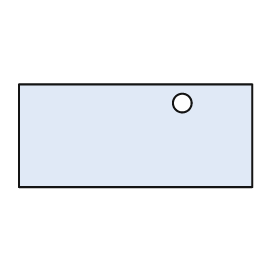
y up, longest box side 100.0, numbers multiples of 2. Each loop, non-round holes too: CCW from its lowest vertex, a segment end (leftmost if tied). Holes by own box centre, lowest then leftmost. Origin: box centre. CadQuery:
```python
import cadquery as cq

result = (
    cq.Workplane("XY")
    .moveTo(-50.0, -22.0)
    .lineTo(50.0, -22.0)
    .lineTo(50.0, 22.0)
    .lineTo(-50.0, 22.0)
    .close()
    .moveTo(20.0, 14.0)
    .circle(4.0)
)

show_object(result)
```